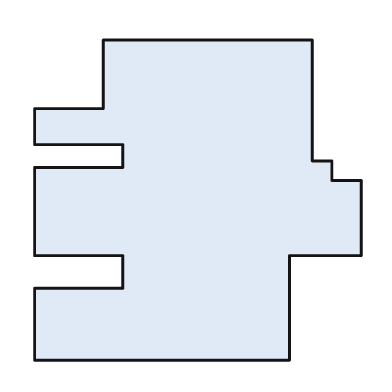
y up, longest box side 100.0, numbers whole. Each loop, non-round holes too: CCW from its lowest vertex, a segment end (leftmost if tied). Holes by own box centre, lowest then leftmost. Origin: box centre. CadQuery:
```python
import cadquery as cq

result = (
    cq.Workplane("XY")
    .moveTo(-50.0, -49.0)
    .lineTo(28.0, -49.0)
    .lineTo(28.0, -17.0)
    .lineTo(50.0, -17.0)
    .lineTo(50.0, 6.0)
    .lineTo(41.0, 6.0)
    .lineTo(41.0, 12.0)
    .lineTo(35.0, 12.0)
    .lineTo(35.0, 49.0)
    .lineTo(-29.0, 49.0)
    .lineTo(-29.0, 28.0)
    .lineTo(-50.0, 28.0)
    .lineTo(-50.0, 17.0)
    .lineTo(-23.0, 17.0)
    .lineTo(-23.0, 10.0)
    .lineTo(-50.0, 10.0)
    .lineTo(-50.0, -17.0)
    .lineTo(-23.0, -17.0)
    .lineTo(-23.0, -27.0)
    .lineTo(-50.0, -27.0)
    .close()
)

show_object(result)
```